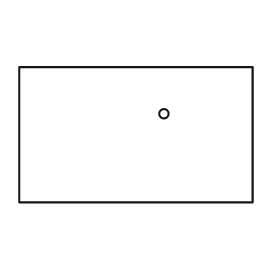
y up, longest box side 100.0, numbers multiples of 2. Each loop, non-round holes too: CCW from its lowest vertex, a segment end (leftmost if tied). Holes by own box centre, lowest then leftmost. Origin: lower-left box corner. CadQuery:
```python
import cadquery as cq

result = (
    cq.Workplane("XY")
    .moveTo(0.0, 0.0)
    .lineTo(100.0, 0.0)
    .lineTo(100.0, 58.0)
    .lineTo(0.0, 58.0)
    .close()
    .moveTo(62.0, 38.0)
    .circle(2.0)
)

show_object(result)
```